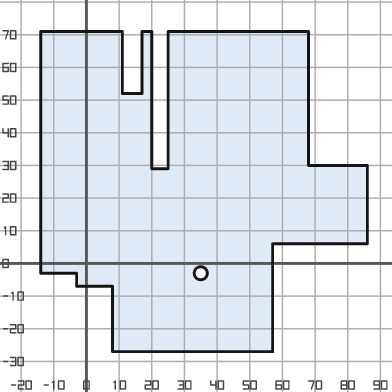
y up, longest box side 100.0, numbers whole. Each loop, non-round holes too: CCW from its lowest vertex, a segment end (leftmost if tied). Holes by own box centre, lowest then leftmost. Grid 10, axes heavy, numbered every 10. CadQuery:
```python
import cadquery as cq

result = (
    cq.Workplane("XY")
    .moveTo(8.0, -27.0)
    .lineTo(57.0, -27.0)
    .lineTo(57.0, 6.0)
    .lineTo(86.0, 6.0)
    .lineTo(86.0, 30.0)
    .lineTo(68.0, 30.0)
    .lineTo(68.0, 71.0)
    .lineTo(25.0, 71.0)
    .lineTo(25.0, 29.0)
    .lineTo(20.0, 29.0)
    .lineTo(20.0, 71.0)
    .lineTo(17.0, 71.0)
    .lineTo(17.0, 52.0)
    .lineTo(11.0, 52.0)
    .lineTo(11.0, 71.0)
    .lineTo(-14.0, 71.0)
    .lineTo(-14.0, -3.0)
    .lineTo(-3.0, -3.0)
    .lineTo(-3.0, -7.0)
    .lineTo(8.0, -7.0)
    .close()
    .moveTo(35.0, -3.0)
    .circle(2.0)
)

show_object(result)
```